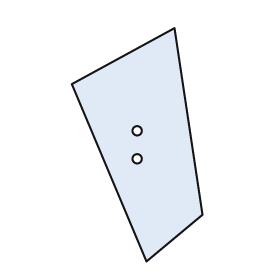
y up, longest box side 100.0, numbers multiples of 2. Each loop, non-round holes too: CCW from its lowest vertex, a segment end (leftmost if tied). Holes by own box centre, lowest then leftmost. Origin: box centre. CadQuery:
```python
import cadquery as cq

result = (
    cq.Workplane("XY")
    .moveTo(4.0, -50.0)
    .lineTo(28.0, -30.0)
    .lineTo(16.0, 50.0)
    .lineTo(-28.0, 26.0)
    .close()
    .moveTo(0.0, -6.0)
    .circle(2.0)
    .moveTo(0.0, 6.0)
    .circle(2.0)
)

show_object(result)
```